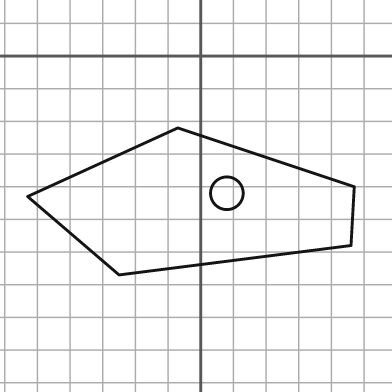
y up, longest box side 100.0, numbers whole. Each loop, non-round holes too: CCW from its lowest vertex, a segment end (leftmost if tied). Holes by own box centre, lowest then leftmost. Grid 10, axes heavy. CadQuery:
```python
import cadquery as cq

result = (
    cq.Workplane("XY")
    .moveTo(-25.0, -67.0)
    .lineTo(46.0, -58.0)
    .lineTo(47.0, -40.0)
    .lineTo(-7.0, -22.0)
    .lineTo(-53.0, -43.0)
    .close()
    .moveTo(8.0, -42.0)
    .circle(5.0)
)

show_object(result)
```